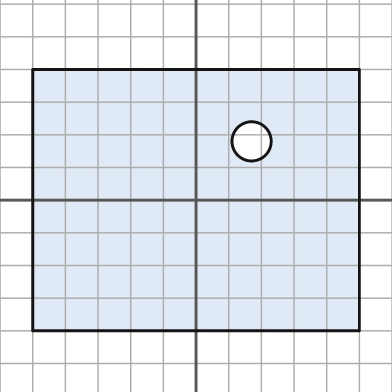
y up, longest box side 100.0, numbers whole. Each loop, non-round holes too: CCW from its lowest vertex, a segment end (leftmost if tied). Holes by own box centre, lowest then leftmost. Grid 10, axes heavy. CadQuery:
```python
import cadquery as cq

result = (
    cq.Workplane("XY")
    .moveTo(-50.0, -40.0)
    .lineTo(50.0, -40.0)
    .lineTo(50.0, 40.0)
    .lineTo(-50.0, 40.0)
    .close()
    .moveTo(17.0, 18.0)
    .circle(6.0)
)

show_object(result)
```